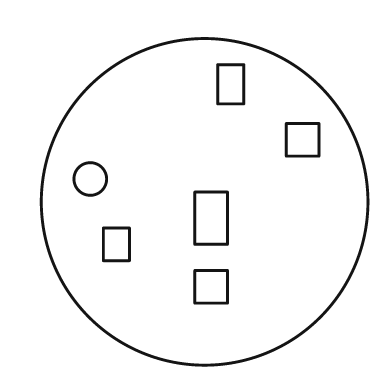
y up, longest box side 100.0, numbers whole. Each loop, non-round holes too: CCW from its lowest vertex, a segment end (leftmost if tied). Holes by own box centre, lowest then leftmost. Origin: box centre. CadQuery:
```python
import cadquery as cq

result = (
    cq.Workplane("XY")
    .moveTo(0.0, 0.0)
    .circle(50.0)
    .moveTo(-3.0, -31.0)
    .lineTo(7.0, -31.0)
    .lineTo(7.0, -21.0)
    .lineTo(-3.0, -21.0)
    .close()
    .moveTo(-31.0, -18.0)
    .lineTo(-23.0, -18.0)
    .lineTo(-23.0, -8.0)
    .lineTo(-31.0, -8.0)
    .close()
    .moveTo(-3.0, -13.0)
    .lineTo(7.0, -13.0)
    .lineTo(7.0, 3.0)
    .lineTo(-3.0, 3.0)
    .close()
    .moveTo(-35.0, 7.0)
    .circle(5.0)
    .moveTo(25.0, 14.0)
    .lineTo(35.0, 14.0)
    .lineTo(35.0, 24.0)
    .lineTo(25.0, 24.0)
    .close()
    .moveTo(4.0, 30.0)
    .lineTo(12.0, 30.0)
    .lineTo(12.0, 42.0)
    .lineTo(4.0, 42.0)
    .close()
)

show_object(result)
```